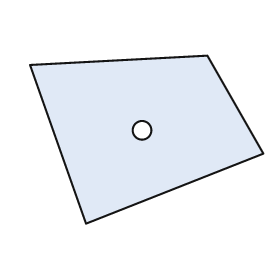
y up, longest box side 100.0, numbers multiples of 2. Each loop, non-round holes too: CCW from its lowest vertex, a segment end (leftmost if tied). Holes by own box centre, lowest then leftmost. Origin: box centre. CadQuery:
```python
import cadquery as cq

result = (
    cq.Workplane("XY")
    .moveTo(-26.0, -36.0)
    .lineTo(50.0, -6.0)
    .lineTo(26.0, 36.0)
    .lineTo(-50.0, 32.0)
    .close()
    .moveTo(-2.0, 4.0)
    .circle(4.0)
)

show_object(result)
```